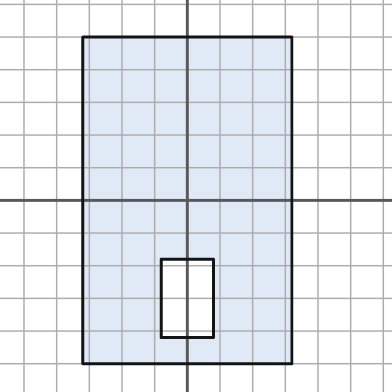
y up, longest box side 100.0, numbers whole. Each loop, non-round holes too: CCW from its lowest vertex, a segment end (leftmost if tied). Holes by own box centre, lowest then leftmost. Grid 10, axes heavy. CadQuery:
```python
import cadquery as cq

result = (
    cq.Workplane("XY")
    .moveTo(-32.0, -50.0)
    .lineTo(32.0, -50.0)
    .lineTo(32.0, 50.0)
    .lineTo(-32.0, 50.0)
    .close()
    .moveTo(-8.0, -42.0)
    .lineTo(8.0, -42.0)
    .lineTo(8.0, -18.0)
    .lineTo(-8.0, -18.0)
    .close()
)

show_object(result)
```